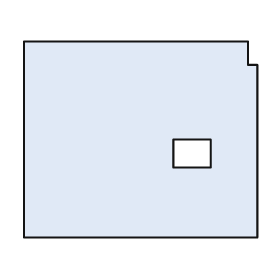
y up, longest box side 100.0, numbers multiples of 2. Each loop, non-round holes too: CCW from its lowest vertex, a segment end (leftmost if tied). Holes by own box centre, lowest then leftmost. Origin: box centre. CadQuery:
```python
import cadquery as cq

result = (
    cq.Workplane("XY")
    .moveTo(-50.0, -42.0)
    .lineTo(50.0, -42.0)
    .lineTo(50.0, 32.0)
    .lineTo(46.0, 32.0)
    .lineTo(46.0, 42.0)
    .lineTo(-50.0, 42.0)
    .close()
    .moveTo(14.0, -12.0)
    .lineTo(30.0, -12.0)
    .lineTo(30.0, 0.0)
    .lineTo(14.0, 0.0)
    .close()
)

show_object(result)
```